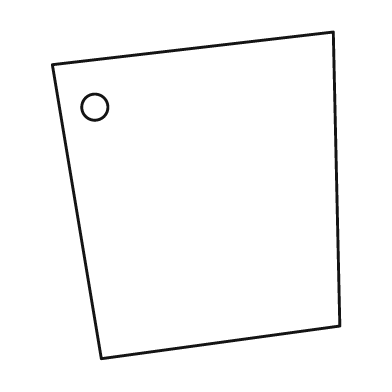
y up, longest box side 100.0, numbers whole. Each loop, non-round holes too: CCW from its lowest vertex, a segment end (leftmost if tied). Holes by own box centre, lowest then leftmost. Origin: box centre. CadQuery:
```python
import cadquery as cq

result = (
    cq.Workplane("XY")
    .moveTo(-29.0, -50.0)
    .lineTo(44.0, -40.0)
    .lineTo(42.0, 50.0)
    .lineTo(-44.0, 40.0)
    .close()
    .moveTo(-31.0, 27.0)
    .circle(4.0)
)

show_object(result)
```